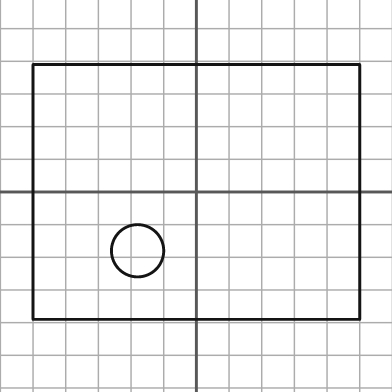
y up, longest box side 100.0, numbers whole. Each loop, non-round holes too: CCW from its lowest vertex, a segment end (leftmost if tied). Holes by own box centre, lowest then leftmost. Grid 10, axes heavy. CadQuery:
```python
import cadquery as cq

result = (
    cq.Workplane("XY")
    .moveTo(-50.0, -39.0)
    .lineTo(50.0, -39.0)
    .lineTo(50.0, 39.0)
    .lineTo(-50.0, 39.0)
    .close()
    .moveTo(-18.0, -18.0)
    .circle(8.0)
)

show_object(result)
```